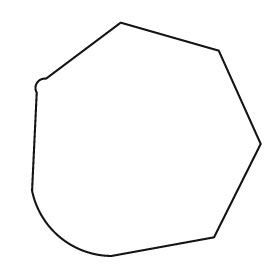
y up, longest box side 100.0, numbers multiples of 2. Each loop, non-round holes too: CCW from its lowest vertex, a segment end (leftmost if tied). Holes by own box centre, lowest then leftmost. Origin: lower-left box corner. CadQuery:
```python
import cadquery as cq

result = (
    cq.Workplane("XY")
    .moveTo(34.0, 0.0)
    .lineTo(78.0, 8.0)
    .lineTo(98.0, 48.0)
    .lineTo(80.0, 88.0)
    .lineTo(38.0, 100.0)
    .lineTo(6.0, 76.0)
    .threePointArc((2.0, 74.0), (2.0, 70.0))
    .lineTo(0.0, 28.0)
    .threePointArc((12.0, 8.0), (34.0, 0.0))
    .close()
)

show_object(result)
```